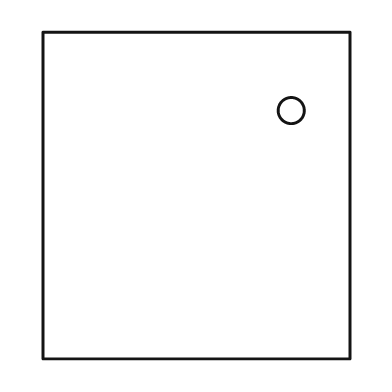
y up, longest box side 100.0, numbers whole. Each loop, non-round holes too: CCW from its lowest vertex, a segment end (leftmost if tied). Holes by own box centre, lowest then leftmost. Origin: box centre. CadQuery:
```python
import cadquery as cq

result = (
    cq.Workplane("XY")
    .moveTo(-47.0, -50.0)
    .lineTo(47.0, -50.0)
    .lineTo(47.0, 50.0)
    .lineTo(-47.0, 50.0)
    .close()
    .moveTo(29.0, 26.0)
    .circle(4.0)
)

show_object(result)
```